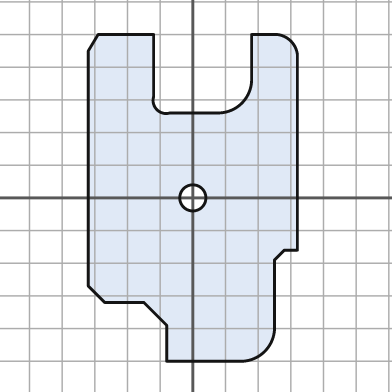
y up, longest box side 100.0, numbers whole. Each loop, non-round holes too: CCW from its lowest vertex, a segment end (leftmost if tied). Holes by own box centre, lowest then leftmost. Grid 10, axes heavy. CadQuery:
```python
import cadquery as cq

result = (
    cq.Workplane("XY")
    .moveTo(-8.0, -50.0)
    .lineTo(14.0, -50.0)
    .threePointArc((22.0, -47.0), (25.0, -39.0))
    .lineTo(25.0, -19.0)
    .lineTo(28.0, -16.0)
    .lineTo(32.0, -16.0)
    .lineTo(32.0, 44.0)
    .threePointArc((30.0, 48.0), (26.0, 50.0))
    .lineTo(18.0, 50.0)
    .lineTo(18.0, 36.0)
    .threePointArc((15.0, 29.0), (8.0, 26.0))
    .lineTo(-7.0, 26.0)
    .threePointArc((-11.0, 27.0), (-12.0, 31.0))
    .lineTo(-12.0, 50.0)
    .lineTo(-29.0, 50.0)
    .lineTo(-32.0, 45.0)
    .lineTo(-32.0, -27.0)
    .lineTo(-27.0, -32.0)
    .lineTo(-15.0, -32.0)
    .lineTo(-8.0, -39.0)
    .close()
    .moveTo(0.0, 0.0)
    .circle(4.0)
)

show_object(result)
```